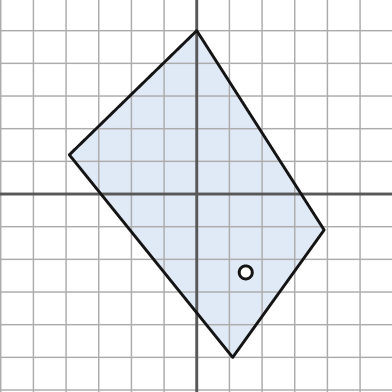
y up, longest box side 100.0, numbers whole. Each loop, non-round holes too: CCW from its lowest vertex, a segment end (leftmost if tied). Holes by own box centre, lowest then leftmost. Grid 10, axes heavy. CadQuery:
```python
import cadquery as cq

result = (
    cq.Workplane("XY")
    .moveTo(11.0, -50.0)
    .lineTo(39.0, -11.0)
    .lineTo(0.0, 50.0)
    .lineTo(-39.0, 12.0)
    .close()
    .moveTo(15.0, -24.0)
    .circle(2.0)
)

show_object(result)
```